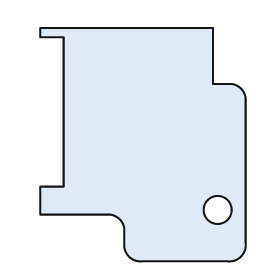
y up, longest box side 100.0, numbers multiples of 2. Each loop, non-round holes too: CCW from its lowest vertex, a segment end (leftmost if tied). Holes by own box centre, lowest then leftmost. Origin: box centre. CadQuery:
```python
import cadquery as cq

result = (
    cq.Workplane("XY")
    .moveTo(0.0, -50.0)
    .lineTo(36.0, -50.0)
    .threePointArc((42.0, -48.0), (44.0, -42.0))
    .lineTo(44.0, 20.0)
    .threePointArc((42.0, 24.0), (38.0, 26.0))
    .lineTo(30.0, 26.0)
    .lineTo(30.0, 50.0)
    .lineTo(-44.0, 50.0)
    .lineTo(-44.0, 46.0)
    .lineTo(-34.0, 46.0)
    .lineTo(-34.0, -18.0)
    .lineTo(-44.0, -18.0)
    .lineTo(-44.0, -30.0)
    .lineTo(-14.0, -30.0)
    .threePointArc((-10.0, -32.0), (-8.0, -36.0))
    .lineTo(-8.0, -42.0)
    .threePointArc((-6.0, -48.0), (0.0, -50.0))
    .close()
    .moveTo(32.0, -28.0)
    .circle(6.0)
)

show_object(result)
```